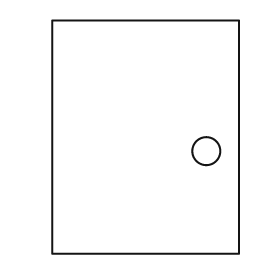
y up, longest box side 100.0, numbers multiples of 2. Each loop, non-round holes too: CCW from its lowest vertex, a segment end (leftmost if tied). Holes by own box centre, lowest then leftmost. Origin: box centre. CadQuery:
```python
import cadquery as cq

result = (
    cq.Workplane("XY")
    .moveTo(-40.0, -50.0)
    .lineTo(40.0, -50.0)
    .lineTo(40.0, 50.0)
    .lineTo(-40.0, 50.0)
    .close()
    .moveTo(26.0, -6.0)
    .circle(6.0)
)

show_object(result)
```